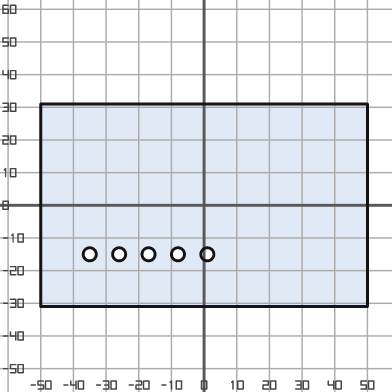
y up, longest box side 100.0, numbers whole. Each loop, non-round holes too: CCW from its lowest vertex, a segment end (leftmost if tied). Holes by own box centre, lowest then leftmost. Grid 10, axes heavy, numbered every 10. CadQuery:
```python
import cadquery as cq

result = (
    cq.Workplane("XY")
    .moveTo(-50.0, -31.0)
    .lineTo(50.0, -31.0)
    .lineTo(50.0, 31.0)
    .lineTo(-50.0, 31.0)
    .close()
    .moveTo(-35.0, -15.0)
    .circle(2.0)
    .moveTo(-26.0, -15.0)
    .circle(2.0)
    .moveTo(-17.0, -15.0)
    .circle(2.0)
    .moveTo(-8.0, -15.0)
    .circle(2.0)
    .moveTo(1.0, -15.0)
    .circle(2.0)
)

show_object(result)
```